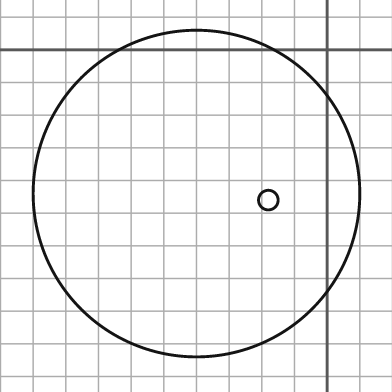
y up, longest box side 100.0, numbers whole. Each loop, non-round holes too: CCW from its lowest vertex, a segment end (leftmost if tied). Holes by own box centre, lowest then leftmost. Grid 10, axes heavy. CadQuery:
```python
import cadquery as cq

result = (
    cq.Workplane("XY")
    .moveTo(-40.0, -44.0)
    .circle(50.0)
    .moveTo(-18.0, -46.0)
    .circle(3.0)
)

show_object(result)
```